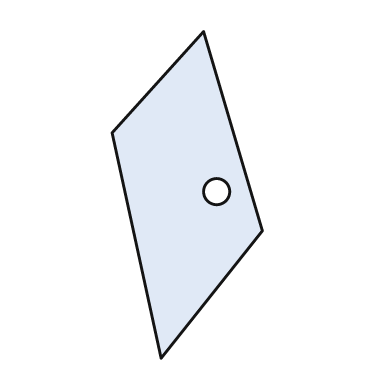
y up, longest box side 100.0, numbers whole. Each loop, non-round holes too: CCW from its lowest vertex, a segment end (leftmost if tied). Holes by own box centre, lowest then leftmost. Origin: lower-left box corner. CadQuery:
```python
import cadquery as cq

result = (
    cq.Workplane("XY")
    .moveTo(15.0, 0.0)
    .lineTo(46.0, 39.0)
    .lineTo(28.0, 100.0)
    .lineTo(0.0, 69.0)
    .close()
    .moveTo(32.0, 51.0)
    .circle(4.0)
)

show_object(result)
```